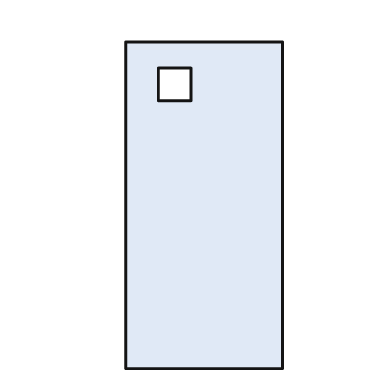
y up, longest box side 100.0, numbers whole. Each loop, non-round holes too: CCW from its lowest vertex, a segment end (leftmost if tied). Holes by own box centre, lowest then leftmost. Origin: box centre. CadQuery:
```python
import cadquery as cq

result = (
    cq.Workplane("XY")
    .moveTo(-24.0, -50.0)
    .lineTo(24.0, -50.0)
    .lineTo(24.0, 50.0)
    .lineTo(-24.0, 50.0)
    .close()
    .moveTo(-14.0, 32.0)
    .lineTo(-4.0, 32.0)
    .lineTo(-4.0, 42.0)
    .lineTo(-14.0, 42.0)
    .close()
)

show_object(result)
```